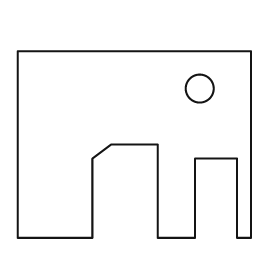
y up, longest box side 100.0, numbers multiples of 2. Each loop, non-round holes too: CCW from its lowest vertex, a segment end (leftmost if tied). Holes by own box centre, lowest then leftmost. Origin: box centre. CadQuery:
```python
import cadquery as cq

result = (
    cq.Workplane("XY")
    .moveTo(-50.0, -40.0)
    .lineTo(-18.0, -40.0)
    .lineTo(-18.0, -6.0)
    .lineTo(-10.0, 0.0)
    .lineTo(10.0, 0.0)
    .lineTo(10.0, -40.0)
    .lineTo(26.0, -40.0)
    .lineTo(26.0, -6.0)
    .lineTo(44.0, -6.0)
    .lineTo(44.0, -40.0)
    .lineTo(50.0, -40.0)
    .lineTo(50.0, 40.0)
    .lineTo(-50.0, 40.0)
    .close()
    .moveTo(28.0, 24.0)
    .circle(6.0)
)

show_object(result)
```